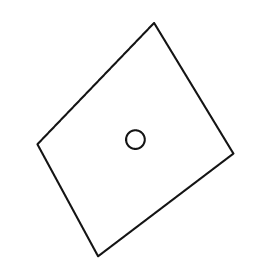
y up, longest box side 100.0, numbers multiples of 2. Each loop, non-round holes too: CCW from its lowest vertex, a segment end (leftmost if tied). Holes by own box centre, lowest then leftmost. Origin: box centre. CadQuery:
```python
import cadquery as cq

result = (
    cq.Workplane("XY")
    .moveTo(-16.0, -50.0)
    .lineTo(42.0, -6.0)
    .lineTo(8.0, 50.0)
    .lineTo(-42.0, -2.0)
    .close()
    .moveTo(0.0, 0.0)
    .circle(4.0)
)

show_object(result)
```